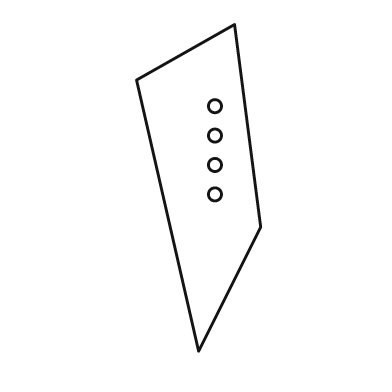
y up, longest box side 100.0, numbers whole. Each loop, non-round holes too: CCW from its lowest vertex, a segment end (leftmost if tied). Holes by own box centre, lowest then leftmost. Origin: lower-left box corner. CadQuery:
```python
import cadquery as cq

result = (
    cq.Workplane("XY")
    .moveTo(19.0, 0.0)
    .lineTo(38.0, 38.0)
    .lineTo(30.0, 100.0)
    .lineTo(0.0, 83.0)
    .close()
    .moveTo(24.0, 48.0)
    .circle(2.0)
    .moveTo(24.0, 57.0)
    .circle(2.0)
    .moveTo(24.0, 66.0)
    .circle(2.0)
    .moveTo(24.0, 75.0)
    .circle(2.0)
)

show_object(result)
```